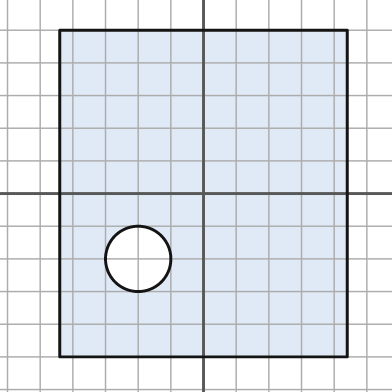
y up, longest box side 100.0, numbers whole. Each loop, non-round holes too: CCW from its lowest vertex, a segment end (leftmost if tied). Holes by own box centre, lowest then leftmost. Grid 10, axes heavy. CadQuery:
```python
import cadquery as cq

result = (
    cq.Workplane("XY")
    .moveTo(-44.0, -50.0)
    .lineTo(44.0, -50.0)
    .lineTo(44.0, 50.0)
    .lineTo(-44.0, 50.0)
    .close()
    .moveTo(-20.0, -20.0)
    .circle(10.0)
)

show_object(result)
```